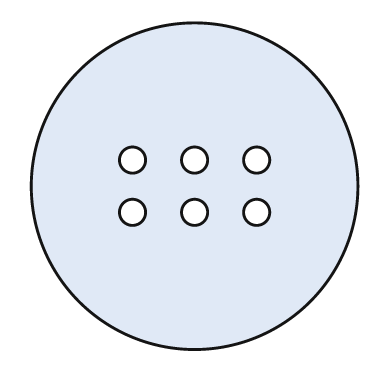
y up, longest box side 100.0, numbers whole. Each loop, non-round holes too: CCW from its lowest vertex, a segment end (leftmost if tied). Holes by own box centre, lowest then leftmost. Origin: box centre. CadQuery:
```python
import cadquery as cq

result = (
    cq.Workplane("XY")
    .moveTo(0.0, 0.0)
    .circle(50.0)
    .moveTo(-19.0, -8.0)
    .circle(4.0)
    .moveTo(0.0, -8.0)
    .circle(4.0)
    .moveTo(19.0, -8.0)
    .circle(4.0)
    .moveTo(-19.0, 8.0)
    .circle(4.0)
    .moveTo(0.0, 8.0)
    .circle(4.0)
    .moveTo(19.0, 8.0)
    .circle(4.0)
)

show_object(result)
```